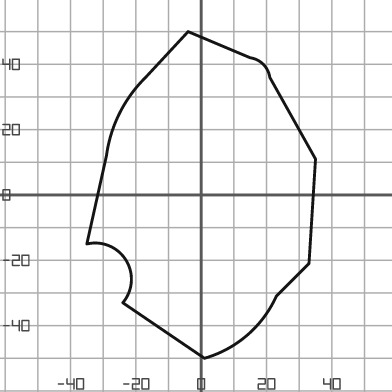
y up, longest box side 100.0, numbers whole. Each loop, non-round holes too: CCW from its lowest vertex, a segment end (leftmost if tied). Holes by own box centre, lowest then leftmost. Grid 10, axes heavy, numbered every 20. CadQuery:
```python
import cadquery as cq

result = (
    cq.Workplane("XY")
    .moveTo(1.0, -50.0)
    .threePointArc((14.0, -43.0), (23.0, -31.0))
    .lineTo(33.0, -21.0)
    .lineTo(35.0, 11.0)
    .lineTo(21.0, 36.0)
    .threePointArc((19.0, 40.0), (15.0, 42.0))
    .lineTo(-4.0, 50.0)
    .lineTo(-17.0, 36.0)
    .threePointArc((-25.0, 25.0), (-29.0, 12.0))
    .lineTo(-35.0, -15.0)
    .threePointArc((-23.0, -20.0), (-24.0, -33.0))
    .close()
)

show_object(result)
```